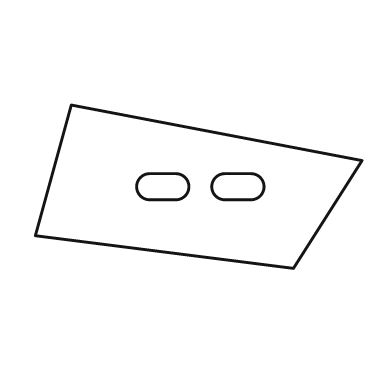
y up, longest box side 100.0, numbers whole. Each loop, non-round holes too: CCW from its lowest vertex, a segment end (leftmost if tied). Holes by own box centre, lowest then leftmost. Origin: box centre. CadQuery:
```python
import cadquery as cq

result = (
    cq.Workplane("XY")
    .moveTo(29.0, -25.0)
    .lineTo(50.0, 8.0)
    .lineTo(-39.0, 25.0)
    .lineTo(-50.0, -15.0)
    .close()
    .moveTo(-15.0, -4.0)
    .lineTo(-7.0, -4.0)
    .threePointArc((-3.0, 0.0), (-7.0, 4.0))
    .lineTo(-15.0, 4.0)
    .threePointArc((-19.0, 0.0), (-15.0, -4.0))
    .close()
    .moveTo(8.0, -4.0)
    .lineTo(16.0, -4.0)
    .threePointArc((20.0, 0.0), (16.0, 4.0))
    .lineTo(8.0, 4.0)
    .threePointArc((4.0, 0.0), (8.0, -4.0))
    .close()
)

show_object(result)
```